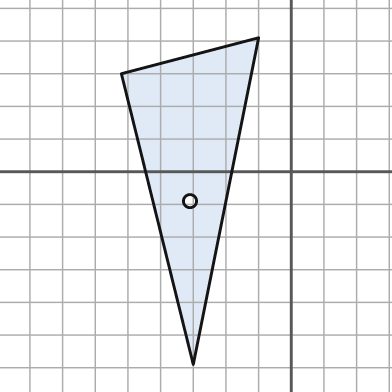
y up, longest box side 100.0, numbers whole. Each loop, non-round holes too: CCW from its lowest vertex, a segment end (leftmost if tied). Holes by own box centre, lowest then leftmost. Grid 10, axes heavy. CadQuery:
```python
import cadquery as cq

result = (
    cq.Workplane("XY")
    .moveTo(-30.0, -59.0)
    .lineTo(-10.0, 41.0)
    .lineTo(-52.0, 30.0)
    .close()
    .moveTo(-31.0, -9.0)
    .circle(2.0)
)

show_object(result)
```